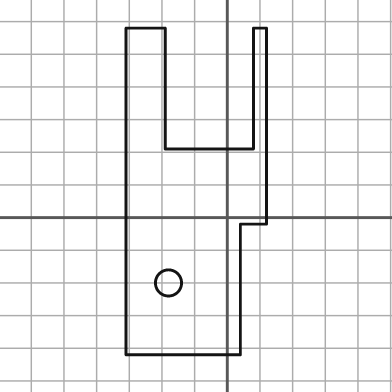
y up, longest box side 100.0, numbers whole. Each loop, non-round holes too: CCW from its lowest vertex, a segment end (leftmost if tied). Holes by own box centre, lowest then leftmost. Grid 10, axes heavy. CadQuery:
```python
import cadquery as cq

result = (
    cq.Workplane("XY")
    .moveTo(-31.0, -42.0)
    .lineTo(4.0, -42.0)
    .lineTo(4.0, -2.0)
    .lineTo(12.0, -2.0)
    .lineTo(12.0, 58.0)
    .lineTo(8.0, 58.0)
    .lineTo(8.0, 21.0)
    .lineTo(-19.0, 21.0)
    .lineTo(-19.0, 58.0)
    .lineTo(-31.0, 58.0)
    .close()
    .moveTo(-18.0, -20.0)
    .circle(4.0)
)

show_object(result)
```